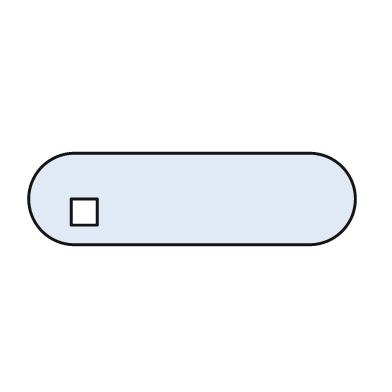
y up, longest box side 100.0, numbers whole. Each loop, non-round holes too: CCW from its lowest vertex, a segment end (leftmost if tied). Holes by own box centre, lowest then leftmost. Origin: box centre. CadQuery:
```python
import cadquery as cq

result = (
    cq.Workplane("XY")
    .moveTo(-36.0, -14.0)
    .lineTo(36.0, -14.0)
    .threePointArc((50.0, 0.0), (36.0, 14.0))
    .lineTo(-36.0, 14.0)
    .threePointArc((-50.0, 0.0), (-36.0, -14.0))
    .close()
    .moveTo(-37.0, -8.0)
    .lineTo(-29.0, -8.0)
    .lineTo(-29.0, 0.0)
    .lineTo(-37.0, 0.0)
    .close()
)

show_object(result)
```